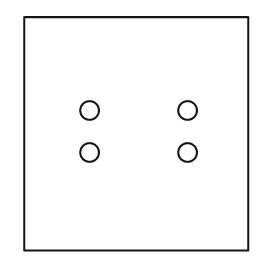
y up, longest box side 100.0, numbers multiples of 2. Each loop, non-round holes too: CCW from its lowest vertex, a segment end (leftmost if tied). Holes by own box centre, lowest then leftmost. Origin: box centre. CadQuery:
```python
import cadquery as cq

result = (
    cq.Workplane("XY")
    .moveTo(-48.0, -50.0)
    .lineTo(48.0, -50.0)
    .lineTo(48.0, 50.0)
    .lineTo(-48.0, 50.0)
    .close()
    .moveTo(-20.0, -8.0)
    .circle(4.0)
    .moveTo(22.0, -8.0)
    .circle(4.0)
    .moveTo(-20.0, 10.0)
    .circle(4.0)
    .moveTo(22.0, 10.0)
    .circle(4.0)
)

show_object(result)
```